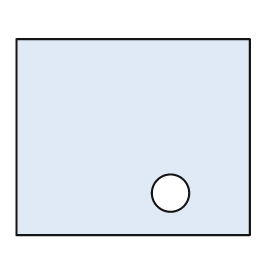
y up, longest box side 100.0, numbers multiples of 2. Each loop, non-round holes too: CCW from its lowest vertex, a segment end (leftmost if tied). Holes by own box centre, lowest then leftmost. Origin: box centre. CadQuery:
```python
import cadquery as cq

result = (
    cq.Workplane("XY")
    .moveTo(-50.0, -42.0)
    .lineTo(50.0, -42.0)
    .lineTo(50.0, 42.0)
    .lineTo(-50.0, 42.0)
    .close()
    .moveTo(16.0, -24.0)
    .circle(8.0)
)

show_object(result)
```